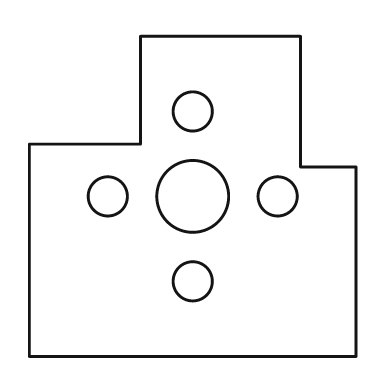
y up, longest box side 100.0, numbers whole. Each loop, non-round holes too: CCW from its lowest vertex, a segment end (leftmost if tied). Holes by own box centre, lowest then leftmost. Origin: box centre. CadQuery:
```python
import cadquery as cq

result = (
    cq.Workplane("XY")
    .moveTo(-50.0, -49.0)
    .lineTo(50.0, -49.0)
    .lineTo(50.0, 9.0)
    .lineTo(33.0, 9.0)
    .lineTo(33.0, 49.0)
    .lineTo(-16.0, 49.0)
    .lineTo(-16.0, 16.0)
    .lineTo(-50.0, 16.0)
    .close()
    .moveTo(0.0, -26.0)
    .circle(6.0)
    .moveTo(-26.0, 0.0)
    .circle(6.0)
    .moveTo(0.0, 0.0)
    .circle(11.0)
    .moveTo(26.0, 0.0)
    .circle(6.0)
    .moveTo(0.0, 26.0)
    .circle(6.0)
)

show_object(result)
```